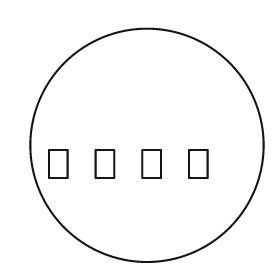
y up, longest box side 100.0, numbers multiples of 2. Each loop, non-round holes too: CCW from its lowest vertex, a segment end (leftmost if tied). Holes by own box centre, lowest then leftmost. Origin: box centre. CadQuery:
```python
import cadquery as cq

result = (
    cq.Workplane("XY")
    .moveTo(0.0, 0.0)
    .circle(50.0)
    .moveTo(-42.0, -14.0)
    .lineTo(-34.0, -14.0)
    .lineTo(-34.0, -2.0)
    .lineTo(-42.0, -2.0)
    .close()
    .moveTo(-22.0, -14.0)
    .lineTo(-14.0, -14.0)
    .lineTo(-14.0, -2.0)
    .lineTo(-22.0, -2.0)
    .close()
    .moveTo(-2.0, -14.0)
    .lineTo(6.0, -14.0)
    .lineTo(6.0, -2.0)
    .lineTo(-2.0, -2.0)
    .close()
    .moveTo(18.0, -14.0)
    .lineTo(26.0, -14.0)
    .lineTo(26.0, -2.0)
    .lineTo(18.0, -2.0)
    .close()
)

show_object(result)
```